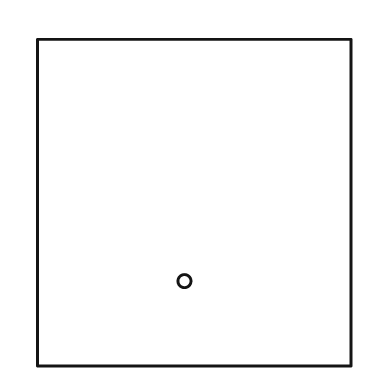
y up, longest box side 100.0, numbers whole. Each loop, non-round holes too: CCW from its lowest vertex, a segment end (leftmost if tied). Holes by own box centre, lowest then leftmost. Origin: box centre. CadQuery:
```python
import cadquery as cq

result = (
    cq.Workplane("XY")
    .moveTo(-48.0, -50.0)
    .lineTo(48.0, -50.0)
    .lineTo(48.0, 50.0)
    .lineTo(-48.0, 50.0)
    .close()
    .moveTo(-3.0, -24.0)
    .circle(2.0)
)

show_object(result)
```